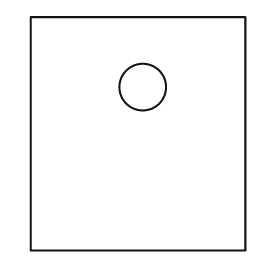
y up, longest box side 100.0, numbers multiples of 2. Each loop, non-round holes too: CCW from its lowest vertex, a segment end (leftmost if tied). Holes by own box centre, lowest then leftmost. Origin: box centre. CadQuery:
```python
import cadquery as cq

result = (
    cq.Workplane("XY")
    .moveTo(-46.0, -50.0)
    .lineTo(46.0, -50.0)
    .lineTo(46.0, 50.0)
    .lineTo(-46.0, 50.0)
    .close()
    .moveTo(2.0, 20.0)
    .circle(10.0)
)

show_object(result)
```